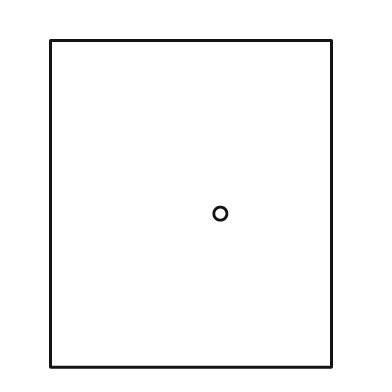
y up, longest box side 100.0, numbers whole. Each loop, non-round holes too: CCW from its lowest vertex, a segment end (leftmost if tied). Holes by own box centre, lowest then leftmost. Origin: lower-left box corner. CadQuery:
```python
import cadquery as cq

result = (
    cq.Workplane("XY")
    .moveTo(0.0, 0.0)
    .lineTo(86.0, 0.0)
    .lineTo(86.0, 100.0)
    .lineTo(0.0, 100.0)
    .close()
    .moveTo(52.0, 47.0)
    .circle(2.0)
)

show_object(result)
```